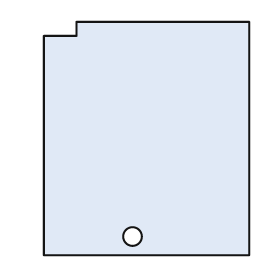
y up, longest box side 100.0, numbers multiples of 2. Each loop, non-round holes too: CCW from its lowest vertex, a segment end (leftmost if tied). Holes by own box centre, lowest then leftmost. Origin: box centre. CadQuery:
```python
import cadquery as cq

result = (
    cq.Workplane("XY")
    .moveTo(-44.0, -50.0)
    .lineTo(44.0, -50.0)
    .lineTo(44.0, 50.0)
    .lineTo(-30.0, 50.0)
    .lineTo(-30.0, 44.0)
    .lineTo(-44.0, 44.0)
    .close()
    .moveTo(-6.0, -42.0)
    .circle(4.0)
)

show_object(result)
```